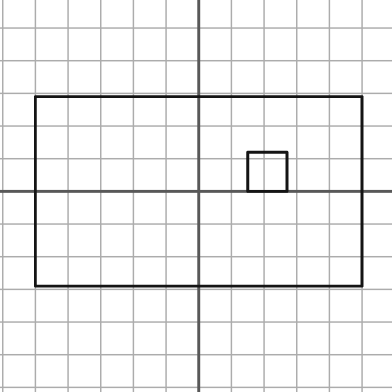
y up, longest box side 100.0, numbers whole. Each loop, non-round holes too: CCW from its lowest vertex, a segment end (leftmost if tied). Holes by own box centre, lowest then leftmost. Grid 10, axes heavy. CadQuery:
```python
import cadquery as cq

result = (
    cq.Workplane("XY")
    .moveTo(-50.0, -29.0)
    .lineTo(50.0, -29.0)
    .lineTo(50.0, 29.0)
    .lineTo(-50.0, 29.0)
    .close()
    .moveTo(15.0, 0.0)
    .lineTo(27.0, 0.0)
    .lineTo(27.0, 12.0)
    .lineTo(15.0, 12.0)
    .close()
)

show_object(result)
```